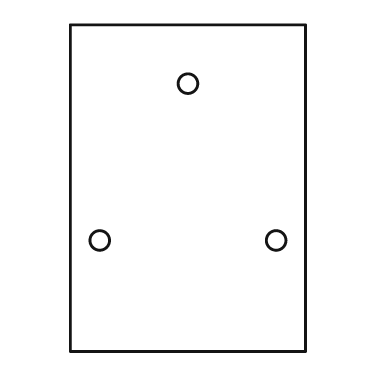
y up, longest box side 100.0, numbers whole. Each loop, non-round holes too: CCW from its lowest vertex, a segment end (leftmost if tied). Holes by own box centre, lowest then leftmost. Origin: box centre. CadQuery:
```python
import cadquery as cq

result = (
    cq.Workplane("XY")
    .moveTo(-36.0, -50.0)
    .lineTo(36.0, -50.0)
    .lineTo(36.0, 50.0)
    .lineTo(-36.0, 50.0)
    .close()
    .moveTo(-27.0, -16.0)
    .circle(3.0)
    .moveTo(27.0, -16.0)
    .circle(3.0)
    .moveTo(0.0, 32.0)
    .circle(3.0)
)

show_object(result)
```